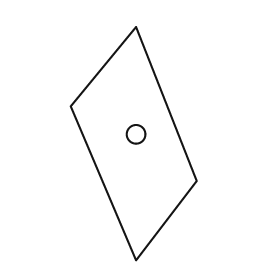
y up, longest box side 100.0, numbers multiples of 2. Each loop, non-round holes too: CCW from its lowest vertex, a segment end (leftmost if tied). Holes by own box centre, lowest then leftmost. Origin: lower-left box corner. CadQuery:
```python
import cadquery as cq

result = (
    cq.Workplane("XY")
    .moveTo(28.0, 0.0)
    .lineTo(54.0, 34.0)
    .lineTo(28.0, 100.0)
    .lineTo(0.0, 66.0)
    .close()
    .moveTo(28.0, 54.0)
    .circle(4.0)
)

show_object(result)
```